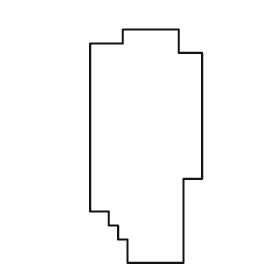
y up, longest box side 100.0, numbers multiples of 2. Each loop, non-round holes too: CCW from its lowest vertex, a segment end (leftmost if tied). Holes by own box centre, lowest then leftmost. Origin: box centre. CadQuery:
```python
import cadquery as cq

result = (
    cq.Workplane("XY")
    .moveTo(-8.0, -50.0)
    .lineTo(16.0, -50.0)
    .lineTo(16.0, -14.0)
    .lineTo(24.0, -14.0)
    .lineTo(24.0, 40.0)
    .lineTo(14.0, 40.0)
    .lineTo(14.0, 50.0)
    .lineTo(-10.0, 50.0)
    .lineTo(-10.0, 44.0)
    .lineTo(-24.0, 44.0)
    .lineTo(-24.0, -28.0)
    .lineTo(-16.0, -28.0)
    .lineTo(-16.0, -34.0)
    .lineTo(-12.0, -34.0)
    .lineTo(-12.0, -40.0)
    .lineTo(-8.0, -40.0)
    .close()
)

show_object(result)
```